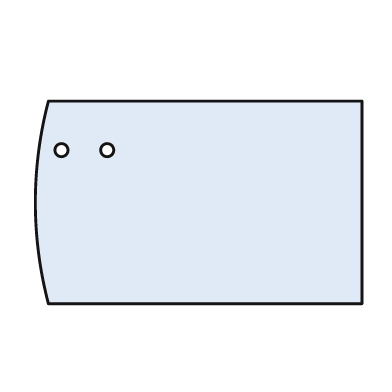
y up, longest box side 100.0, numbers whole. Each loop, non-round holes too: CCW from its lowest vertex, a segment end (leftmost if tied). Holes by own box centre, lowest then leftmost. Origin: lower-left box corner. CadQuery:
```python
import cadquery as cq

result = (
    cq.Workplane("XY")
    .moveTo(4.0, 0.0)
    .lineTo(100.0, 0.0)
    .lineTo(100.0, 62.0)
    .lineTo(4.0, 62.0)
    .threePointArc((0.0, 31.0), (4.0, 0.0))
    .close()
    .moveTo(8.0, 47.0)
    .circle(2.0)
    .moveTo(22.0, 47.0)
    .circle(2.0)
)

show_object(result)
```